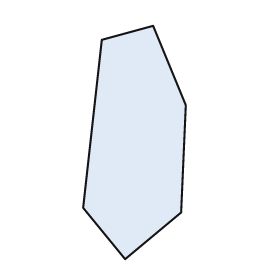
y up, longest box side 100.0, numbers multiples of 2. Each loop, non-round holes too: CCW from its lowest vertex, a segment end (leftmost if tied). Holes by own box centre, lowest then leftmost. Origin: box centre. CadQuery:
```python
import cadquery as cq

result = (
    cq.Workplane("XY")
    .moveTo(-4.0, -50.0)
    .lineTo(20.0, -30.0)
    .lineTo(22.0, 16.0)
    .lineTo(8.0, 50.0)
    .lineTo(-14.0, 44.0)
    .lineTo(-22.0, -28.0)
    .close()
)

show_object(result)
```